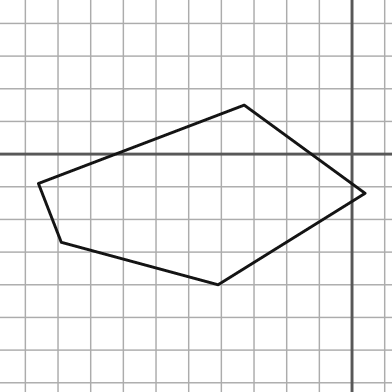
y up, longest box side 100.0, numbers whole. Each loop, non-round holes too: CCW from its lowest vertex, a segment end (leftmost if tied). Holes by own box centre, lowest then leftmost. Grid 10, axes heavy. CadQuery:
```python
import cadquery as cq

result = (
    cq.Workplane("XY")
    .moveTo(-41.0, -40.0)
    .lineTo(4.0, -12.0)
    .lineTo(-33.0, 15.0)
    .lineTo(-96.0, -9.0)
    .lineTo(-89.0, -27.0)
    .close()
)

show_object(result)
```